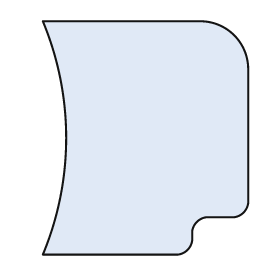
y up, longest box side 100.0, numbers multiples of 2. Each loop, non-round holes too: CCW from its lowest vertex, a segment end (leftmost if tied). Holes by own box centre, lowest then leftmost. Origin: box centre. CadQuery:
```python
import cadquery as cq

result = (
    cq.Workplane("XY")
    .moveTo(-44.0, -50.0)
    .lineTo(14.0, -50.0)
    .threePointArc((18.0, -48.0), (20.0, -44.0))
    .lineTo(20.0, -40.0)
    .threePointArc((22.0, -36.0), (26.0, -34.0))
    .lineTo(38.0, -34.0)
    .threePointArc((42.0, -32.0), (44.0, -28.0))
    .lineTo(44.0, 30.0)
    .threePointArc((38.0, 44.0), (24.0, 50.0))
    .lineTo(-44.0, 50.0)
    .threePointArc((-34.0, 0.0), (-44.0, -50.0))
    .close()
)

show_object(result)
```